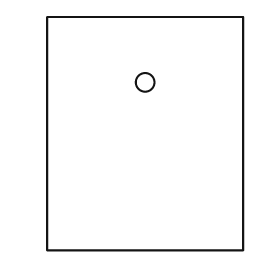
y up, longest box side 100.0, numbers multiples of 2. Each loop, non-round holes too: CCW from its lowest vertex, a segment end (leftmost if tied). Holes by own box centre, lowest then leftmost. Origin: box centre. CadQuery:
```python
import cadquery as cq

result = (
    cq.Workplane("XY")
    .moveTo(-42.0, -50.0)
    .lineTo(42.0, -50.0)
    .lineTo(42.0, 50.0)
    .lineTo(-42.0, 50.0)
    .close()
    .moveTo(0.0, 22.0)
    .circle(4.0)
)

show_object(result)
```